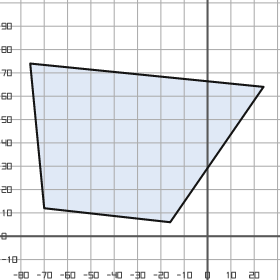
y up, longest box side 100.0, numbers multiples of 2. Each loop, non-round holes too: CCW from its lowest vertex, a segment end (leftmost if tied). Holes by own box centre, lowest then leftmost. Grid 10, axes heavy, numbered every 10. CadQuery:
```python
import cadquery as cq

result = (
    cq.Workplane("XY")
    .moveTo(-16.0, 6.0)
    .lineTo(24.0, 64.0)
    .lineTo(-76.0, 74.0)
    .lineTo(-70.0, 12.0)
    .close()
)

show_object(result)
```